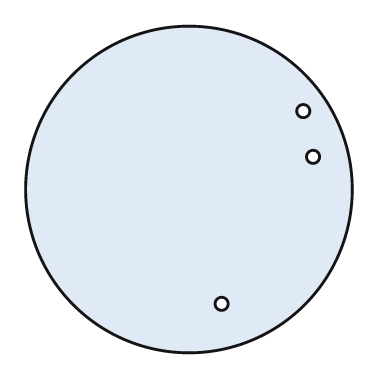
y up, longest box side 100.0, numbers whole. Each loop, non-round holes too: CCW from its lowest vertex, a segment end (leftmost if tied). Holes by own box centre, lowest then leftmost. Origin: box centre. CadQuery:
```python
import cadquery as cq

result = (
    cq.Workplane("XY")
    .moveTo(0.0, 0.0)
    .circle(50.0)
    .moveTo(10.0, -35.0)
    .circle(2.0)
    .moveTo(38.0, 10.0)
    .circle(2.0)
    .moveTo(35.0, 24.0)
    .circle(2.0)
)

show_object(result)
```